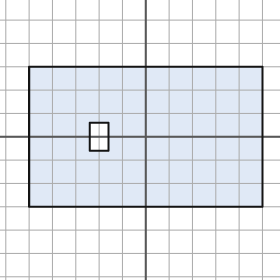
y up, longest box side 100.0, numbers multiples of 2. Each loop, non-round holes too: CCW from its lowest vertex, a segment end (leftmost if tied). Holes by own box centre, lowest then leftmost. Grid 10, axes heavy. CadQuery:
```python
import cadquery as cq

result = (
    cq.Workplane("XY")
    .moveTo(-50.0, -30.0)
    .lineTo(50.0, -30.0)
    .lineTo(50.0, 30.0)
    .lineTo(-50.0, 30.0)
    .close()
    .moveTo(-24.0, -6.0)
    .lineTo(-16.0, -6.0)
    .lineTo(-16.0, 6.0)
    .lineTo(-24.0, 6.0)
    .close()
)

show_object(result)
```